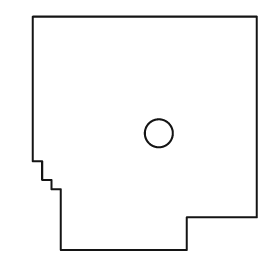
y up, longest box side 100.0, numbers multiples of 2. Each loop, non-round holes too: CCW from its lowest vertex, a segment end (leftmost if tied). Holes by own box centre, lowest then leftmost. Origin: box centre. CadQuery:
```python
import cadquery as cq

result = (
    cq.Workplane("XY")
    .moveTo(-36.0, -50.0)
    .lineTo(18.0, -50.0)
    .lineTo(18.0, -36.0)
    .lineTo(48.0, -36.0)
    .lineTo(48.0, 50.0)
    .lineTo(-48.0, 50.0)
    .lineTo(-48.0, -12.0)
    .lineTo(-44.0, -12.0)
    .lineTo(-44.0, -20.0)
    .lineTo(-40.0, -20.0)
    .lineTo(-40.0, -24.0)
    .lineTo(-36.0, -24.0)
    .close()
    .moveTo(6.0, 0.0)
    .circle(6.0)
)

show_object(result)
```